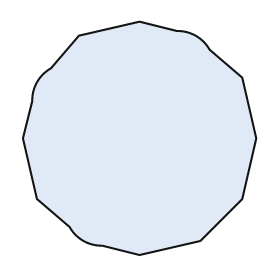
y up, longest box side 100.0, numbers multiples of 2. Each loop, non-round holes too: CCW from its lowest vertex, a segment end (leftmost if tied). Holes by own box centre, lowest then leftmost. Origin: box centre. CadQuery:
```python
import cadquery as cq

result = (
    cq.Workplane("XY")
    .moveTo(0.0, -50.0)
    .lineTo(26.0, -44.0)
    .lineTo(44.0, -26.0)
    .lineTo(50.0, 0.0)
    .lineTo(44.0, 26.0)
    .lineTo(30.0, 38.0)
    .threePointArc((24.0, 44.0), (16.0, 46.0))
    .lineTo(0.0, 50.0)
    .lineTo(-26.0, 44.0)
    .lineTo(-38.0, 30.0)
    .threePointArc((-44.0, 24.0), (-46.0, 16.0))
    .lineTo(-50.0, 0.0)
    .lineTo(-44.0, -26.0)
    .lineTo(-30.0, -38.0)
    .threePointArc((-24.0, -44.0), (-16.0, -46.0))
    .close()
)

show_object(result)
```